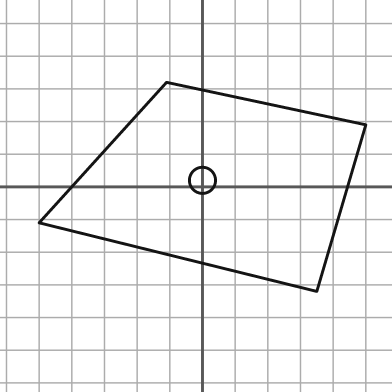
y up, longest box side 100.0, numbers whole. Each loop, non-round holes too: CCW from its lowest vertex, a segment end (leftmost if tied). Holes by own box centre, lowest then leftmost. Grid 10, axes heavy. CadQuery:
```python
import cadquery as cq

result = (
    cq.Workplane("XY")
    .moveTo(35.0, -32.0)
    .lineTo(50.0, 19.0)
    .lineTo(-11.0, 32.0)
    .lineTo(-50.0, -11.0)
    .close()
    .moveTo(0.0, 2.0)
    .circle(4.0)
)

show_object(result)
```